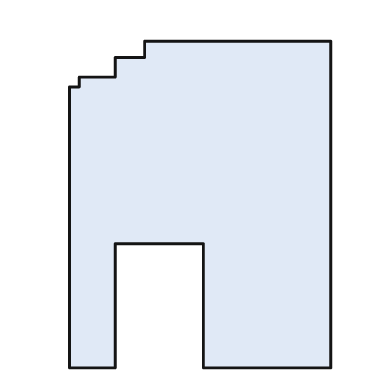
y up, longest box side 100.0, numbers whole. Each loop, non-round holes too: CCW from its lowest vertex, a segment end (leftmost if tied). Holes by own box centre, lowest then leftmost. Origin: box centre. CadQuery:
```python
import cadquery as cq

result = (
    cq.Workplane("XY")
    .moveTo(-40.0, -50.0)
    .lineTo(-26.0, -50.0)
    .lineTo(-26.0, -12.0)
    .lineTo(1.0, -12.0)
    .lineTo(1.0, -50.0)
    .lineTo(40.0, -50.0)
    .lineTo(40.0, 50.0)
    .lineTo(-17.0, 50.0)
    .lineTo(-17.0, 45.0)
    .lineTo(-26.0, 45.0)
    .lineTo(-26.0, 39.0)
    .lineTo(-37.0, 39.0)
    .lineTo(-37.0, 36.0)
    .lineTo(-40.0, 36.0)
    .close()
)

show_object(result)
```